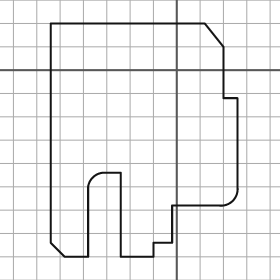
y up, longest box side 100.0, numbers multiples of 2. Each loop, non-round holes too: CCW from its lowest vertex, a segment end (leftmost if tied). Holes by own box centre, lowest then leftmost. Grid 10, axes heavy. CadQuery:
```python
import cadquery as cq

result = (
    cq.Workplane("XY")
    .moveTo(-48.0, -80.0)
    .lineTo(-38.0, -80.0)
    .lineTo(-38.0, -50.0)
    .threePointArc((-36.0, -46.0), (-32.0, -44.0))
    .lineTo(-24.0, -44.0)
    .lineTo(-24.0, -80.0)
    .lineTo(-10.0, -80.0)
    .lineTo(-10.0, -74.0)
    .lineTo(-2.0, -74.0)
    .lineTo(-2.0, -58.0)
    .lineTo(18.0, -58.0)
    .threePointArc((24.0, -56.0), (26.0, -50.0))
    .lineTo(26.0, -12.0)
    .lineTo(20.0, -12.0)
    .lineTo(20.0, 10.0)
    .lineTo(12.0, 20.0)
    .lineTo(-54.0, 20.0)
    .lineTo(-54.0, -74.0)
    .close()
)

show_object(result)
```